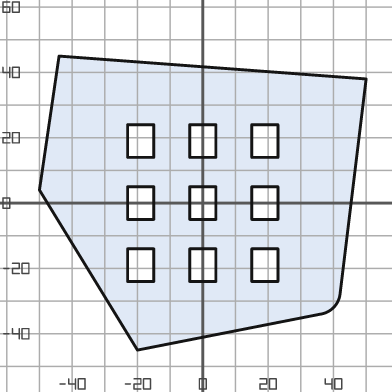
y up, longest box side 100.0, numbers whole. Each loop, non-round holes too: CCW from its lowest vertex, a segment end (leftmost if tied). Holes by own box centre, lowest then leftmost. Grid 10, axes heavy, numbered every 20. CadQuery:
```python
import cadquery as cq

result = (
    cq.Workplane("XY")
    .moveTo(-20.0, -45.0)
    .lineTo(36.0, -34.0)
    .threePointArc((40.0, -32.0), (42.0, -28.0))
    .lineTo(50.0, 38.0)
    .lineTo(-44.0, 45.0)
    .lineTo(-50.0, 4.0)
    .close()
    .moveTo(-23.0, -24.0)
    .lineTo(-15.0, -24.0)
    .lineTo(-15.0, -14.0)
    .lineTo(-23.0, -14.0)
    .close()
    .moveTo(-4.0, -24.0)
    .lineTo(4.0, -24.0)
    .lineTo(4.0, -14.0)
    .lineTo(-4.0, -14.0)
    .close()
    .moveTo(15.0, -24.0)
    .lineTo(23.0, -24.0)
    .lineTo(23.0, -14.0)
    .lineTo(15.0, -14.0)
    .close()
    .moveTo(-23.0, -5.0)
    .lineTo(-15.0, -5.0)
    .lineTo(-15.0, 5.0)
    .lineTo(-23.0, 5.0)
    .close()
    .moveTo(-4.0, -5.0)
    .lineTo(4.0, -5.0)
    .lineTo(4.0, 5.0)
    .lineTo(-4.0, 5.0)
    .close()
    .moveTo(15.0, -5.0)
    .lineTo(23.0, -5.0)
    .lineTo(23.0, 5.0)
    .lineTo(15.0, 5.0)
    .close()
    .moveTo(-23.0, 14.0)
    .lineTo(-15.0, 14.0)
    .lineTo(-15.0, 24.0)
    .lineTo(-23.0, 24.0)
    .close()
    .moveTo(-4.0, 14.0)
    .lineTo(4.0, 14.0)
    .lineTo(4.0, 24.0)
    .lineTo(-4.0, 24.0)
    .close()
    .moveTo(15.0, 14.0)
    .lineTo(23.0, 14.0)
    .lineTo(23.0, 24.0)
    .lineTo(15.0, 24.0)
    .close()
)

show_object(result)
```